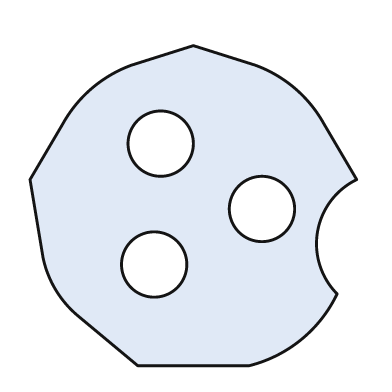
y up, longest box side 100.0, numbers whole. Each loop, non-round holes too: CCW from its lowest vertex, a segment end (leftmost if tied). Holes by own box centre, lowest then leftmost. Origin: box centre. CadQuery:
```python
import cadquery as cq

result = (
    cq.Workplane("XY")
    .moveTo(-17.0, -49.0)
    .lineTo(17.0, -49.0)
    .threePointArc((33.0, -41.0), (44.0, -27.0))
    .threePointArc((38.0, -8.0), (50.0, 8.0))
    .lineTo(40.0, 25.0)
    .threePointArc((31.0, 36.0), (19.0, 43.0))
    .lineTo(0.0, 49.0)
    .lineTo(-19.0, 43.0)
    .threePointArc((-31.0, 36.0), (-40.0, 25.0))
    .lineTo(-50.0, 8.0)
    .lineTo(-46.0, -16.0)
    .threePointArc((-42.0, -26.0), (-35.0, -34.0))
    .close()
    .moveTo(-12.0, -18.0)
    .circle(10.0)
    .moveTo(21.0, -1.0)
    .circle(10.0)
    .moveTo(-10.0, 19.0)
    .circle(10.0)
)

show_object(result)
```